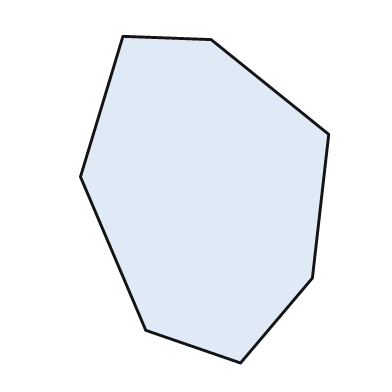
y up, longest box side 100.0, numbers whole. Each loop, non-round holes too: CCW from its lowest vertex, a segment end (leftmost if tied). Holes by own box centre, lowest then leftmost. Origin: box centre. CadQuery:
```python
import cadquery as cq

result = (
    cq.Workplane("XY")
    .moveTo(11.0, -50.0)
    .lineTo(33.0, -24.0)
    .lineTo(38.0, 20.0)
    .lineTo(2.0, 49.0)
    .lineTo(-25.0, 50.0)
    .lineTo(-38.0, 7.0)
    .lineTo(-18.0, -40.0)
    .close()
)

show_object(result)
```